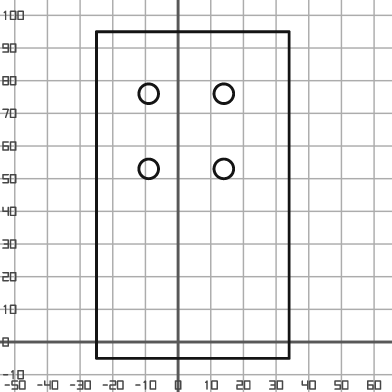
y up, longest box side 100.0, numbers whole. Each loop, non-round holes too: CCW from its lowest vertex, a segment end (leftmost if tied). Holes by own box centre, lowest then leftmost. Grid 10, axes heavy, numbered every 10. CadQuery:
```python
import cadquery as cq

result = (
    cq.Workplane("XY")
    .moveTo(-25.0, -5.0)
    .lineTo(34.0, -5.0)
    .lineTo(34.0, 95.0)
    .lineTo(-25.0, 95.0)
    .close()
    .moveTo(-9.0, 53.0)
    .circle(3.0)
    .moveTo(14.0, 53.0)
    .circle(3.0)
    .moveTo(-9.0, 76.0)
    .circle(3.0)
    .moveTo(14.0, 76.0)
    .circle(3.0)
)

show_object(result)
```